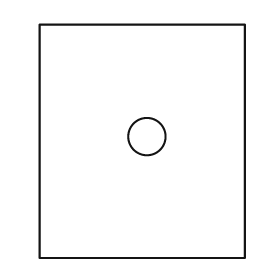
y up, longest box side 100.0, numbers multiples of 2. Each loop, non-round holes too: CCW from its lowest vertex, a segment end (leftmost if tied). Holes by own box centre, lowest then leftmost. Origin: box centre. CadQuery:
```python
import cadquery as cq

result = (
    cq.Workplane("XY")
    .moveTo(-44.0, -50.0)
    .lineTo(44.0, -50.0)
    .lineTo(44.0, 50.0)
    .lineTo(-44.0, 50.0)
    .close()
    .moveTo(2.0, 2.0)
    .circle(8.0)
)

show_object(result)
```